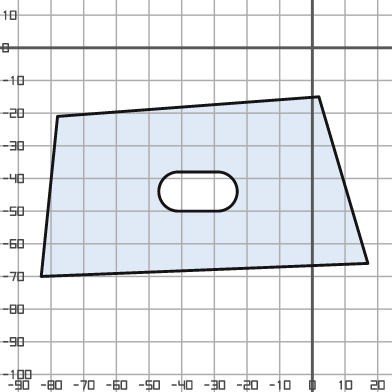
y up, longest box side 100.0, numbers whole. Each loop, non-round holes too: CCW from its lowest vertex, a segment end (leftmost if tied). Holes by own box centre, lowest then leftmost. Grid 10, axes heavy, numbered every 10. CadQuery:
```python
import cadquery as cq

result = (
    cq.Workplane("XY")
    .moveTo(-83.0, -70.0)
    .lineTo(17.0, -66.0)
    .lineTo(2.0, -15.0)
    .lineTo(-78.0, -21.0)
    .close()
    .moveTo(-41.0, -50.0)
    .lineTo(-29.0, -50.0)
    .threePointArc((-23.0, -44.0), (-29.0, -38.0))
    .lineTo(-41.0, -38.0)
    .threePointArc((-47.0, -44.0), (-41.0, -50.0))
    .close()
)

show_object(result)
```